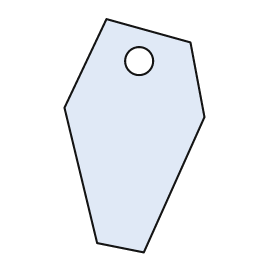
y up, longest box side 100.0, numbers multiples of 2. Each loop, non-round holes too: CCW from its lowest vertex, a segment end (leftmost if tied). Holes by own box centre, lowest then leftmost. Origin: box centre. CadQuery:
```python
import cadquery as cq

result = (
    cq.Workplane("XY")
    .moveTo(4.0, -50.0)
    .lineTo(30.0, 8.0)
    .lineTo(24.0, 40.0)
    .lineTo(-12.0, 50.0)
    .lineTo(-30.0, 12.0)
    .lineTo(-16.0, -46.0)
    .close()
    .moveTo(2.0, 32.0)
    .circle(6.0)
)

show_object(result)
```